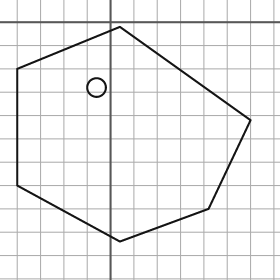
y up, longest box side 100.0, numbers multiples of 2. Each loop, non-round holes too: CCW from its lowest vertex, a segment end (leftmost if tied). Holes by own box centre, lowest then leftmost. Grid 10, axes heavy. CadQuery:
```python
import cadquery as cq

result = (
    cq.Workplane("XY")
    .moveTo(4.0, -94.0)
    .lineTo(42.0, -80.0)
    .lineTo(60.0, -42.0)
    .lineTo(4.0, -2.0)
    .lineTo(-40.0, -20.0)
    .lineTo(-40.0, -70.0)
    .close()
    .moveTo(-6.0, -28.0)
    .circle(4.0)
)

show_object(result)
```